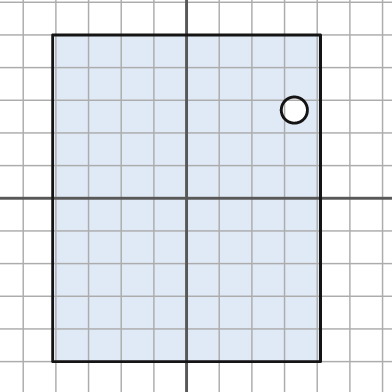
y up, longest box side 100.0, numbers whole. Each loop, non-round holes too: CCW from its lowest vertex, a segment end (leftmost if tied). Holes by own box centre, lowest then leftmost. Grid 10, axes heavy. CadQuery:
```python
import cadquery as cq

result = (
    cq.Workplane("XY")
    .moveTo(-41.0, -50.0)
    .lineTo(41.0, -50.0)
    .lineTo(41.0, 50.0)
    .lineTo(-41.0, 50.0)
    .close()
    .moveTo(33.0, 27.0)
    .circle(4.0)
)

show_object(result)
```